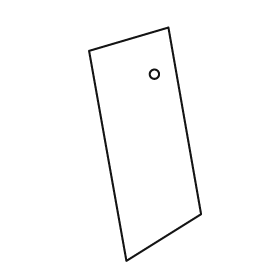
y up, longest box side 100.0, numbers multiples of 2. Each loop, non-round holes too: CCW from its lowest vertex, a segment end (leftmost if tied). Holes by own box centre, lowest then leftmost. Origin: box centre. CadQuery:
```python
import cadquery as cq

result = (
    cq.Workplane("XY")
    .moveTo(-8.0, -50.0)
    .lineTo(24.0, -30.0)
    .lineTo(10.0, 50.0)
    .lineTo(-24.0, 40.0)
    .close()
    .moveTo(4.0, 30.0)
    .circle(2.0)
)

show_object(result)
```